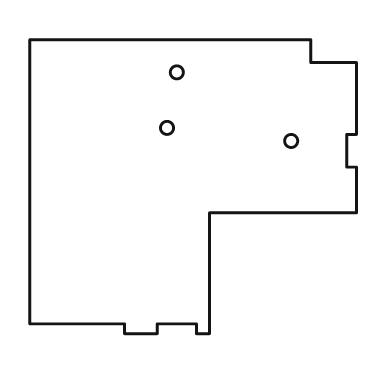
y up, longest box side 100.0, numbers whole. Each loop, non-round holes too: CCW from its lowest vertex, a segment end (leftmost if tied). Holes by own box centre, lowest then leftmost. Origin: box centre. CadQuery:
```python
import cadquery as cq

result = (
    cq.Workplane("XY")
    .moveTo(-21.0, -45.0)
    .lineTo(-11.0, -45.0)
    .lineTo(-11.0, -42.0)
    .lineTo(1.0, -42.0)
    .lineTo(1.0, -45.0)
    .lineTo(5.0, -45.0)
    .lineTo(5.0, -8.0)
    .lineTo(50.0, -8.0)
    .lineTo(50.0, 6.0)
    .lineTo(47.0, 6.0)
    .lineTo(47.0, 16.0)
    .lineTo(50.0, 16.0)
    .lineTo(50.0, 38.0)
    .lineTo(36.0, 38.0)
    .lineTo(36.0, 45.0)
    .lineTo(-50.0, 45.0)
    .lineTo(-50.0, -42.0)
    .lineTo(-21.0, -42.0)
    .close()
    .moveTo(30.0, 14.0)
    .circle(2.0)
    .moveTo(-8.0, 18.0)
    .circle(2.0)
    .moveTo(-5.0, 35.0)
    .circle(2.0)
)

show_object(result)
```